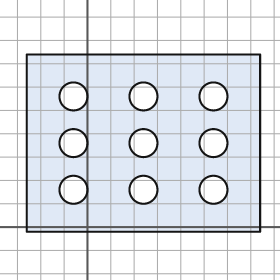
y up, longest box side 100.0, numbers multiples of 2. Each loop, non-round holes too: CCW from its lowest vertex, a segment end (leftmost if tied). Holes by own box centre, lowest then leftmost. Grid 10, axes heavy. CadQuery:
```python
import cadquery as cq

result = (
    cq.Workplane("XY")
    .moveTo(-26.0, -2.0)
    .lineTo(74.0, -2.0)
    .lineTo(74.0, 74.0)
    .lineTo(-26.0, 74.0)
    .close()
    .moveTo(-6.0, 16.0)
    .circle(6.0)
    .moveTo(24.0, 16.0)
    .circle(6.0)
    .moveTo(54.0, 16.0)
    .circle(6.0)
    .moveTo(-6.0, 36.0)
    .circle(6.0)
    .moveTo(24.0, 36.0)
    .circle(6.0)
    .moveTo(54.0, 36.0)
    .circle(6.0)
    .moveTo(-6.0, 56.0)
    .circle(6.0)
    .moveTo(24.0, 56.0)
    .circle(6.0)
    .moveTo(54.0, 56.0)
    .circle(6.0)
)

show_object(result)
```